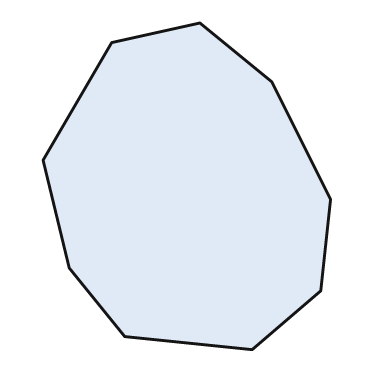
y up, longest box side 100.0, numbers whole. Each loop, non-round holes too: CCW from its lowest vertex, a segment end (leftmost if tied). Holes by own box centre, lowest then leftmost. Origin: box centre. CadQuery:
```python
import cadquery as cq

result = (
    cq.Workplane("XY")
    .moveTo(20.0, -50.0)
    .lineTo(41.0, -32.0)
    .lineTo(44.0, -4.0)
    .lineTo(26.0, 32.0)
    .lineTo(4.0, 50.0)
    .lineTo(-23.0, 44.0)
    .lineTo(-44.0, 8.0)
    .lineTo(-36.0, -25.0)
    .lineTo(-19.0, -46.0)
    .close()
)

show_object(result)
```